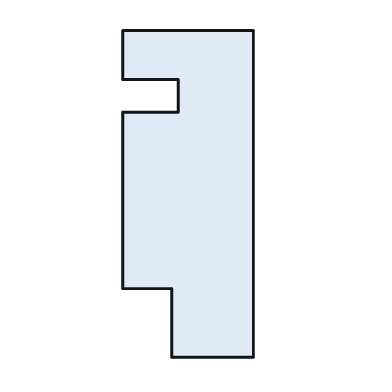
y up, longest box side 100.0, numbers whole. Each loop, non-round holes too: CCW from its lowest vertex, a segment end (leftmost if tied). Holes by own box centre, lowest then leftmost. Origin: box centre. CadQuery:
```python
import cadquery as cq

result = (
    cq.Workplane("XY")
    .moveTo(-5.0, -50.0)
    .lineTo(20.0, -50.0)
    .lineTo(20.0, 50.0)
    .lineTo(-20.0, 50.0)
    .lineTo(-20.0, 35.0)
    .lineTo(-3.0, 35.0)
    .lineTo(-3.0, 25.0)
    .lineTo(-20.0, 25.0)
    .lineTo(-20.0, -29.0)
    .lineTo(-5.0, -29.0)
    .close()
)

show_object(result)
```